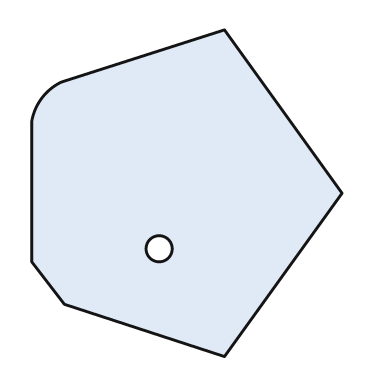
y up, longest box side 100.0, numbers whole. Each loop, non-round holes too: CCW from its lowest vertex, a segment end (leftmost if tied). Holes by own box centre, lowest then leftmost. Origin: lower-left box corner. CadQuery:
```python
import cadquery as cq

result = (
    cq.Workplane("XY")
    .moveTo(59.0, 0.0)
    .lineTo(95.0, 50.0)
    .lineTo(59.0, 100.0)
    .lineTo(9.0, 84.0)
    .threePointArc((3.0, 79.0), (0.0, 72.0))
    .lineTo(0.0, 29.0)
    .lineTo(10.0, 16.0)
    .close()
    .moveTo(39.0, 33.0)
    .circle(4.0)
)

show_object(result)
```